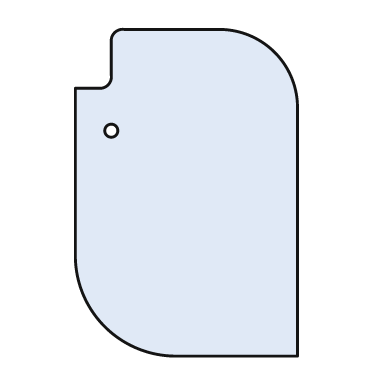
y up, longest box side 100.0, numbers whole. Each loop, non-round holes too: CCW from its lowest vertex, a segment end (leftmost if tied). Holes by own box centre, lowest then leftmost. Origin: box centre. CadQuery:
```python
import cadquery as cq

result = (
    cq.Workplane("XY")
    .moveTo(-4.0, -50.0)
    .lineTo(34.0, -50.0)
    .lineTo(34.0, 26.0)
    .threePointArc((27.0, 43.0), (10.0, 50.0))
    .lineTo(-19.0, 50.0)
    .threePointArc((-22.0, 49.0), (-23.0, 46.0))
    .lineTo(-23.0, 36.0)
    .threePointArc((-24.0, 33.0), (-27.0, 32.0))
    .lineTo(-34.0, 32.0)
    .lineTo(-34.0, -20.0)
    .threePointArc((-25.0, -41.0), (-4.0, -50.0))
    .close()
    .moveTo(-23.0, 19.0)
    .circle(2.0)
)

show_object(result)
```